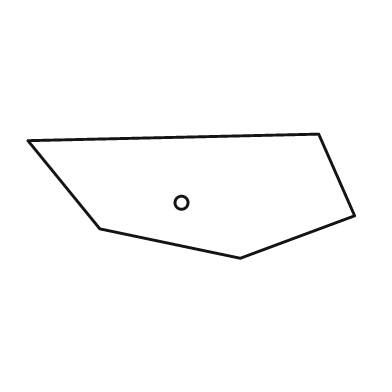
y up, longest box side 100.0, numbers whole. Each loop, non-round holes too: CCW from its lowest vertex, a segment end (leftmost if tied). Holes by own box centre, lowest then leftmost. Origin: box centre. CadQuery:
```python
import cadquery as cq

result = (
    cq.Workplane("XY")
    .moveTo(15.0, -19.0)
    .lineTo(50.0, -6.0)
    .lineTo(39.0, 19.0)
    .lineTo(-50.0, 17.0)
    .lineTo(-28.0, -10.0)
    .close()
    .moveTo(-3.0, -2.0)
    .circle(2.0)
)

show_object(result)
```